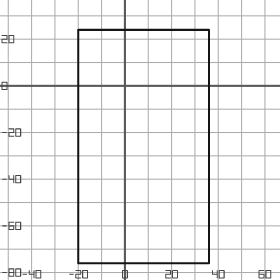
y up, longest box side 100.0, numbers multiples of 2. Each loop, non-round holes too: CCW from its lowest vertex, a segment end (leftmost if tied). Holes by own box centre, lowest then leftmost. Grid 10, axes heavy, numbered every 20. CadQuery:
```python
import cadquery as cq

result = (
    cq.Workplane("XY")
    .moveTo(-20.0, -76.0)
    .lineTo(36.0, -76.0)
    .lineTo(36.0, 24.0)
    .lineTo(-20.0, 24.0)
    .close()
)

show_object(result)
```